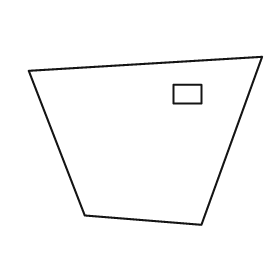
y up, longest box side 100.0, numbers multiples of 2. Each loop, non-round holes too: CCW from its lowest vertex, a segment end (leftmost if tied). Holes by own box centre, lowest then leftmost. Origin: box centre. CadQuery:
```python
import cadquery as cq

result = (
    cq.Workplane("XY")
    .moveTo(24.0, -36.0)
    .lineTo(50.0, 36.0)
    .lineTo(-50.0, 30.0)
    .lineTo(-26.0, -32.0)
    .close()
    .moveTo(12.0, 16.0)
    .lineTo(24.0, 16.0)
    .lineTo(24.0, 24.0)
    .lineTo(12.0, 24.0)
    .close()
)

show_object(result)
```